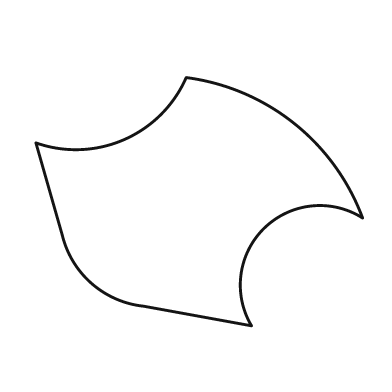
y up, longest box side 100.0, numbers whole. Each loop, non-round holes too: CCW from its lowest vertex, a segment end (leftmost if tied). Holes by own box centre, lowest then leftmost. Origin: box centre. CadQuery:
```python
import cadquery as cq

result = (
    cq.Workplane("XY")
    .moveTo(16.0, -38.0)
    .threePointArc((20.0, -8.0), (50.0, -5.0))
    .threePointArc((29.0, 24.0), (-4.0, 38.0))
    .threePointArc((-23.0, 19.0), (-50.0, 18.0))
    .lineTo(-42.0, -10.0)
    .threePointArc((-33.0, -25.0), (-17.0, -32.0))
    .close()
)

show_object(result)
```